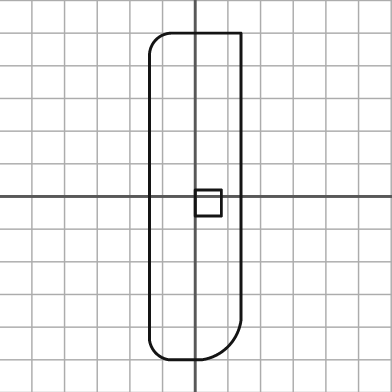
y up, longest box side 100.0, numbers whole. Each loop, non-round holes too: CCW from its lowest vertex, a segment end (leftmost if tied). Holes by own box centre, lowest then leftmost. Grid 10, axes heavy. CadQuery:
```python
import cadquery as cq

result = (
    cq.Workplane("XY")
    .moveTo(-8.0, -50.0)
    .lineTo(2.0, -50.0)
    .threePointArc((10.0, -46.0), (14.0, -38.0))
    .lineTo(14.0, 50.0)
    .lineTo(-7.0, 50.0)
    .threePointArc((-12.0, 48.0), (-14.0, 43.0))
    .lineTo(-14.0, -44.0)
    .threePointArc((-12.0, -48.0), (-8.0, -50.0))
    .close()
    .moveTo(0.0, -6.0)
    .lineTo(8.0, -6.0)
    .lineTo(8.0, 2.0)
    .lineTo(0.0, 2.0)
    .close()
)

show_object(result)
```